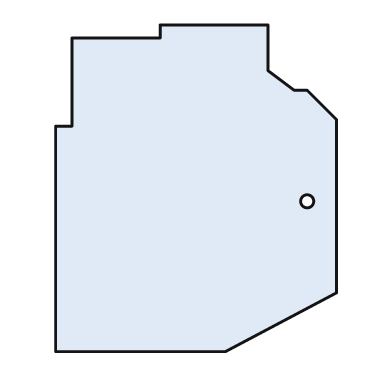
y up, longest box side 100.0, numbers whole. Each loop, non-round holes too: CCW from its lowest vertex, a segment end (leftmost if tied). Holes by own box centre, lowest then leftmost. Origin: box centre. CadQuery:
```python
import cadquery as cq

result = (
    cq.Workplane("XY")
    .moveTo(-43.0, -50.0)
    .lineTo(9.0, -50.0)
    .lineTo(43.0, -32.0)
    .lineTo(43.0, 21.0)
    .lineTo(34.0, 30.0)
    .lineTo(30.0, 30.0)
    .lineTo(22.0, 36.0)
    .lineTo(22.0, 50.0)
    .lineTo(-11.0, 50.0)
    .lineTo(-11.0, 46.0)
    .lineTo(-38.0, 46.0)
    .lineTo(-38.0, 19.0)
    .lineTo(-43.0, 19.0)
    .close()
    .moveTo(34.0, -4.0)
    .circle(2.0)
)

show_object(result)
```